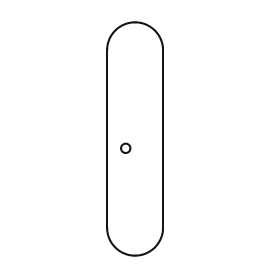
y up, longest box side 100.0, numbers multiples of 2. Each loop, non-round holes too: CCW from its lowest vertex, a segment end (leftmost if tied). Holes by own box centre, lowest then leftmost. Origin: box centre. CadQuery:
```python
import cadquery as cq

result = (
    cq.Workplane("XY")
    .moveTo(-12.0, -38.0)
    .threePointArc((0.0, -50.0), (12.0, -38.0))
    .lineTo(12.0, 38.0)
    .threePointArc((0.0, 50.0), (-12.0, 38.0))
    .close()
    .moveTo(-4.0, -4.0)
    .circle(2.0)
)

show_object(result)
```